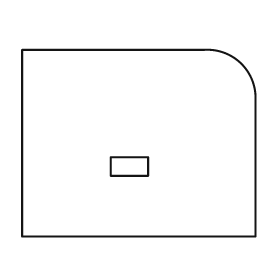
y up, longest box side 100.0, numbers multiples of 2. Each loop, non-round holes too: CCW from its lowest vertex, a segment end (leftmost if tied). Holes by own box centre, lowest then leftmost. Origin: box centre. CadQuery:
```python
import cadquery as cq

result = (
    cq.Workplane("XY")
    .moveTo(-50.0, -40.0)
    .lineTo(50.0, -40.0)
    .lineTo(50.0, 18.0)
    .threePointArc((44.0, 34.0), (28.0, 40.0))
    .lineTo(-50.0, 40.0)
    .close()
    .moveTo(-12.0, -14.0)
    .lineTo(4.0, -14.0)
    .lineTo(4.0, -6.0)
    .lineTo(-12.0, -6.0)
    .close()
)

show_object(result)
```